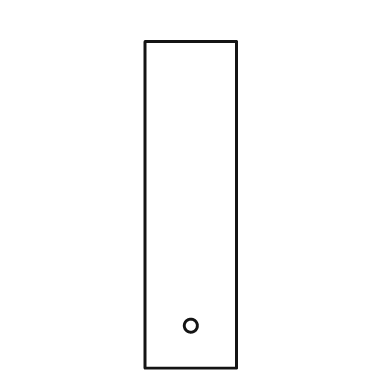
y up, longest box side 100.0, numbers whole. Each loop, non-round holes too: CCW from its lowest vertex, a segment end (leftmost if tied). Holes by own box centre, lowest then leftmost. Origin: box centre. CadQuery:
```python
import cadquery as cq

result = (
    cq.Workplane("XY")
    .moveTo(-14.0, -50.0)
    .lineTo(14.0, -50.0)
    .lineTo(14.0, 50.0)
    .lineTo(-14.0, 50.0)
    .close()
    .moveTo(0.0, -37.0)
    .circle(2.0)
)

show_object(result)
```